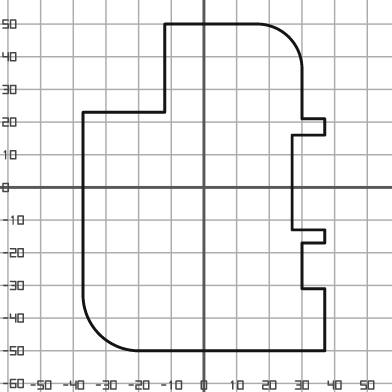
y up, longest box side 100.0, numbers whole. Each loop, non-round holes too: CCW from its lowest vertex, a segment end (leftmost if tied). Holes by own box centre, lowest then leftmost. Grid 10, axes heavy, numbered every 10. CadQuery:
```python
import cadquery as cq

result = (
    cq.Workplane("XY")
    .moveTo(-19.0, -50.0)
    .lineTo(37.0, -50.0)
    .lineTo(37.0, -31.0)
    .lineTo(30.0, -31.0)
    .lineTo(30.0, -17.0)
    .lineTo(37.0, -17.0)
    .lineTo(37.0, -13.0)
    .lineTo(27.0, -13.0)
    .lineTo(27.0, 16.0)
    .lineTo(37.0, 16.0)
    .lineTo(37.0, 21.0)
    .lineTo(30.0, 21.0)
    .lineTo(30.0, 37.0)
    .threePointArc((26.0, 46.0), (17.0, 50.0))
    .lineTo(-12.0, 50.0)
    .lineTo(-12.0, 23.0)
    .lineTo(-37.0, 23.0)
    .lineTo(-37.0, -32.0)
    .threePointArc((-32.0, -45.0), (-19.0, -50.0))
    .close()
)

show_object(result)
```